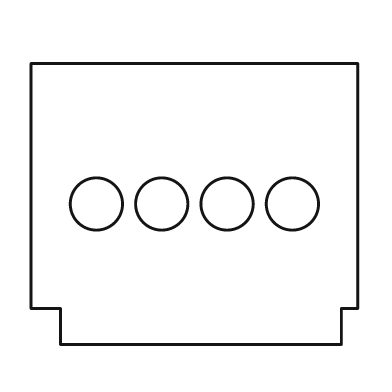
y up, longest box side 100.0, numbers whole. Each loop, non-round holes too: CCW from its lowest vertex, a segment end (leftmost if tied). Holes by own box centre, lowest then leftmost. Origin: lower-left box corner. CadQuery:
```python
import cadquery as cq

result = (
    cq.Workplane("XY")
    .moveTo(9.0, 0.0)
    .lineTo(95.0, 0.0)
    .lineTo(95.0, 11.0)
    .lineTo(100.0, 11.0)
    .lineTo(100.0, 86.0)
    .lineTo(0.0, 86.0)
    .lineTo(0.0, 11.0)
    .lineTo(9.0, 11.0)
    .close()
    .moveTo(20.0, 43.0)
    .circle(8.0)
    .moveTo(40.0, 43.0)
    .circle(8.0)
    .moveTo(60.0, 43.0)
    .circle(8.0)
    .moveTo(80.0, 43.0)
    .circle(8.0)
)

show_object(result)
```